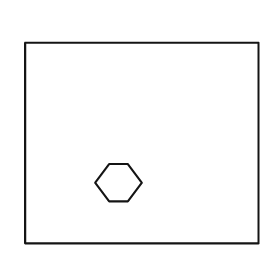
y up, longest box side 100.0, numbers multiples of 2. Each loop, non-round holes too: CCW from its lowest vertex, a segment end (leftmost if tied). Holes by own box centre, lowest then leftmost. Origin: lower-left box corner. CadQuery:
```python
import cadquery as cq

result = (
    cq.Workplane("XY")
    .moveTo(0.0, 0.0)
    .lineTo(100.0, 0.0)
    .lineTo(100.0, 86.0)
    .lineTo(0.0, 86.0)
    .close()
    .moveTo(36.0, 18.0)
    .lineTo(44.0, 18.0)
    .lineTo(50.0, 26.0)
    .lineTo(44.0, 34.0)
    .lineTo(36.0, 34.0)
    .lineTo(30.0, 26.0)
    .close()
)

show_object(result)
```